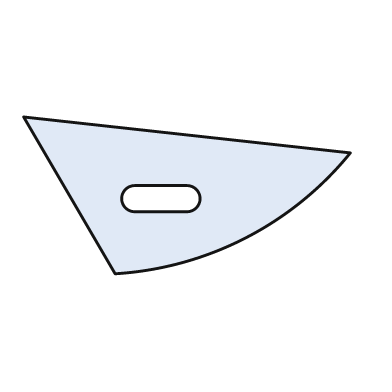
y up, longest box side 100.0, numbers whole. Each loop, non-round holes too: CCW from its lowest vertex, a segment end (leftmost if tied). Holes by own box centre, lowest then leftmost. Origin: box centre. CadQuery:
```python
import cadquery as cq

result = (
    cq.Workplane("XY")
    .moveTo(-22.0, -24.0)
    .threePointArc((18.0, -13.0), (50.0, 13.0))
    .lineTo(-50.0, 24.0)
    .close()
    .moveTo(-16.0, -5.0)
    .lineTo(0.0, -5.0)
    .threePointArc((4.0, -1.0), (0.0, 3.0))
    .lineTo(-16.0, 3.0)
    .threePointArc((-20.0, -1.0), (-16.0, -5.0))
    .close()
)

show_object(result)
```